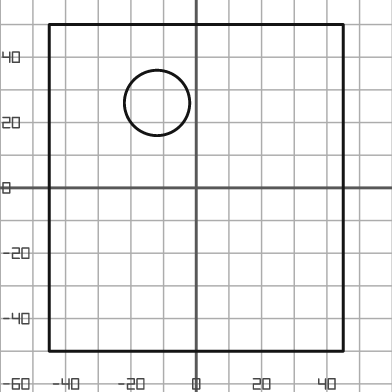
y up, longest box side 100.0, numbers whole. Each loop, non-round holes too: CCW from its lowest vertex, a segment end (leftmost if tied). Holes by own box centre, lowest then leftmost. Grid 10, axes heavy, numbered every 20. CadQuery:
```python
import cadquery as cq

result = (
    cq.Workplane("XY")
    .moveTo(-45.0, -50.0)
    .lineTo(45.0, -50.0)
    .lineTo(45.0, 50.0)
    .lineTo(-45.0, 50.0)
    .close()
    .moveTo(-12.0, 26.0)
    .circle(10.0)
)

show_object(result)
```